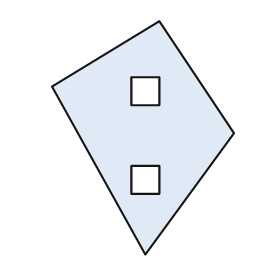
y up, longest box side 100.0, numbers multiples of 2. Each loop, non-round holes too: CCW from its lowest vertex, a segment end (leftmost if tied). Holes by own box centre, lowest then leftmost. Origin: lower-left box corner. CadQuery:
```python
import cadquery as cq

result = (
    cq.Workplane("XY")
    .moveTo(40.0, 0.0)
    .lineTo(78.0, 52.0)
    .lineTo(46.0, 100.0)
    .lineTo(0.0, 72.0)
    .close()
    .moveTo(34.0, 26.0)
    .lineTo(46.0, 26.0)
    .lineTo(46.0, 38.0)
    .lineTo(34.0, 38.0)
    .close()
    .moveTo(34.0, 64.0)
    .lineTo(46.0, 64.0)
    .lineTo(46.0, 76.0)
    .lineTo(34.0, 76.0)
    .close()
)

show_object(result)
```